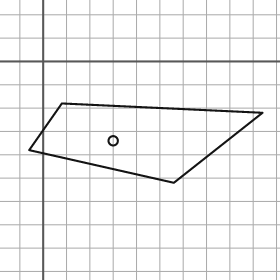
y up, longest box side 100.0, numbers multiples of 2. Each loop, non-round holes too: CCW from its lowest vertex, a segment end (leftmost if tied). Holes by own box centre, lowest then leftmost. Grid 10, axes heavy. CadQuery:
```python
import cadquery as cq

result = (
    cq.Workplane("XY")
    .moveTo(56.0, -52.0)
    .lineTo(94.0, -22.0)
    .lineTo(8.0, -18.0)
    .lineTo(-6.0, -38.0)
    .close()
    .moveTo(30.0, -34.0)
    .circle(2.0)
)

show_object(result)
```